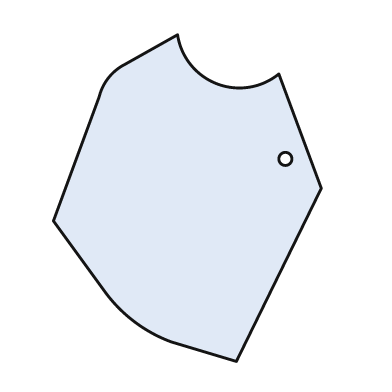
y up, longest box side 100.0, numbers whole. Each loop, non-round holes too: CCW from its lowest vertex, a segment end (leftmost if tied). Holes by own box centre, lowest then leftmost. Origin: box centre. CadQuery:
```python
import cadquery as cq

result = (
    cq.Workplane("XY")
    .moveTo(15.0, -50.0)
    .lineTo(41.0, 3.0)
    .lineTo(28.0, 38.0)
    .threePointArc((9.0, 35.0), (-3.0, 50.0))
    .lineTo(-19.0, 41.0)
    .threePointArc((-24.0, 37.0), (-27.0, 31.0))
    .lineTo(-41.0, -7.0)
    .lineTo(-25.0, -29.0)
    .threePointArc((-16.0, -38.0), (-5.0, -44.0))
    .close()
    .moveTo(30.0, 12.0)
    .circle(2.0)
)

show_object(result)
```